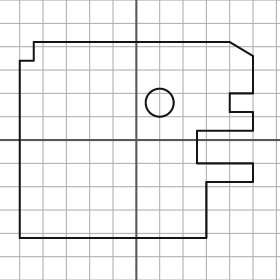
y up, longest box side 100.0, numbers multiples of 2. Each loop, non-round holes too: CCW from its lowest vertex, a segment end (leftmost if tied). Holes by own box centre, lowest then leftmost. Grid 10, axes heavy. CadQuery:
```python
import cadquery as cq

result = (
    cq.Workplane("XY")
    .moveTo(-50.0, -42.0)
    .lineTo(30.0, -42.0)
    .lineTo(30.0, -18.0)
    .lineTo(50.0, -18.0)
    .lineTo(50.0, -10.0)
    .lineTo(26.0, -10.0)
    .lineTo(26.0, 4.0)
    .lineTo(50.0, 4.0)
    .lineTo(50.0, 12.0)
    .lineTo(40.0, 12.0)
    .lineTo(40.0, 20.0)
    .lineTo(50.0, 20.0)
    .lineTo(50.0, 36.0)
    .lineTo(40.0, 42.0)
    .lineTo(-44.0, 42.0)
    .lineTo(-44.0, 34.0)
    .lineTo(-50.0, 34.0)
    .close()
    .moveTo(10.0, 16.0)
    .circle(6.0)
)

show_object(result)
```